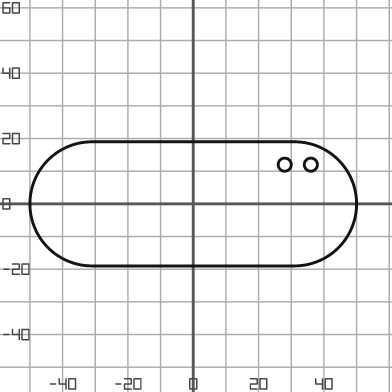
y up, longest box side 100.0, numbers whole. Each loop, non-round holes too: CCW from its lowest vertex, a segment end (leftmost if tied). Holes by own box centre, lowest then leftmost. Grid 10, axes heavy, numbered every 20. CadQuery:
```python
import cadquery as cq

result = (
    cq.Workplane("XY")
    .moveTo(-31.0, -19.0)
    .lineTo(31.0, -19.0)
    .threePointArc((50.0, 0.0), (31.0, 19.0))
    .lineTo(-31.0, 19.0)
    .threePointArc((-50.0, 0.0), (-31.0, -19.0))
    .close()
    .moveTo(28.0, 12.0)
    .circle(2.0)
    .moveTo(36.0, 12.0)
    .circle(2.0)
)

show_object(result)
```